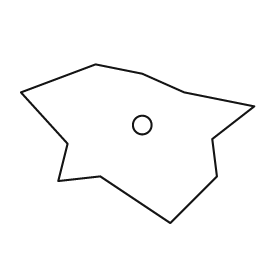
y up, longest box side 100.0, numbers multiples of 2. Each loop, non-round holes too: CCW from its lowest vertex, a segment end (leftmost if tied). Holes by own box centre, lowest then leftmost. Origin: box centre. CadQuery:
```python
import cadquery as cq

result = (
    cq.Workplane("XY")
    .moveTo(14.0, -34.0)
    .lineTo(34.0, -14.0)
    .lineTo(32.0, 2.0)
    .lineTo(50.0, 16.0)
    .lineTo(20.0, 22.0)
    .lineTo(2.0, 30.0)
    .lineTo(-18.0, 34.0)
    .lineTo(-50.0, 22.0)
    .lineTo(-30.0, 0.0)
    .lineTo(-34.0, -16.0)
    .lineTo(-16.0, -14.0)
    .close()
    .moveTo(2.0, 8.0)
    .circle(4.0)
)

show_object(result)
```